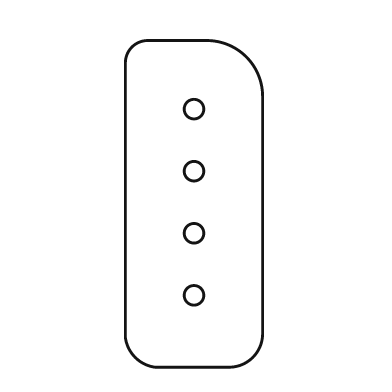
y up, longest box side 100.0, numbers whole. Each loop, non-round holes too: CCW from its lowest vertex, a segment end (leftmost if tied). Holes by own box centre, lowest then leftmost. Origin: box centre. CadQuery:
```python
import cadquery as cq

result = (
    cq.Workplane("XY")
    .moveTo(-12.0, -50.0)
    .lineTo(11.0, -50.0)
    .threePointArc((18.0, -47.0), (21.0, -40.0))
    .lineTo(21.0, 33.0)
    .threePointArc((16.0, 45.0), (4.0, 50.0))
    .lineTo(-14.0, 50.0)
    .threePointArc((-19.0, 48.0), (-21.0, 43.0))
    .lineTo(-21.0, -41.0)
    .threePointArc((-18.0, -47.0), (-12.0, -50.0))
    .close()
    .moveTo(0.0, -28.0)
    .circle(3.0)
    .moveTo(0.0, -9.0)
    .circle(3.0)
    .moveTo(0.0, 10.0)
    .circle(3.0)
    .moveTo(0.0, 29.0)
    .circle(3.0)
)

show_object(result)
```